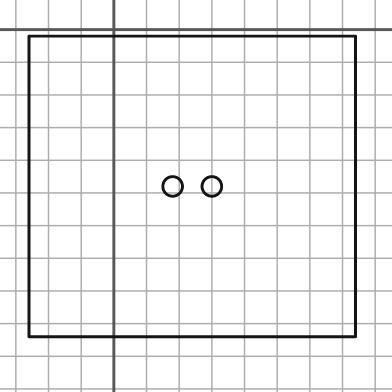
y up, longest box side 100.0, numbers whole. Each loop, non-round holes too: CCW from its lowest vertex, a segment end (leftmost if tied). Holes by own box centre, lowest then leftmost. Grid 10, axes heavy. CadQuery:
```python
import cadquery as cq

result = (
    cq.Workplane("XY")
    .moveTo(-26.0, -94.0)
    .lineTo(74.0, -94.0)
    .lineTo(74.0, -2.0)
    .lineTo(-26.0, -2.0)
    .close()
    .moveTo(18.0, -48.0)
    .circle(3.0)
    .moveTo(30.0, -48.0)
    .circle(3.0)
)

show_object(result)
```